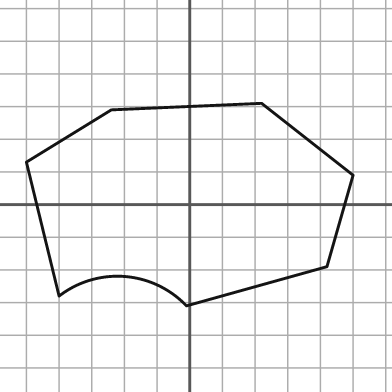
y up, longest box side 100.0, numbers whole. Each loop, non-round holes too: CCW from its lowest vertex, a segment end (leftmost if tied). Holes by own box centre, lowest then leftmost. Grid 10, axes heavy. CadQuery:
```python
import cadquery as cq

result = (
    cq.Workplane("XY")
    .moveTo(-1.0, -31.0)
    .lineTo(42.0, -19.0)
    .lineTo(50.0, 9.0)
    .lineTo(22.0, 31.0)
    .lineTo(-24.0, 29.0)
    .lineTo(-50.0, 13.0)
    .lineTo(-40.0, -28.0)
    .threePointArc((-20.0, -22.0), (-1.0, -31.0))
    .close()
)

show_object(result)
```